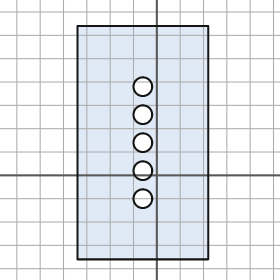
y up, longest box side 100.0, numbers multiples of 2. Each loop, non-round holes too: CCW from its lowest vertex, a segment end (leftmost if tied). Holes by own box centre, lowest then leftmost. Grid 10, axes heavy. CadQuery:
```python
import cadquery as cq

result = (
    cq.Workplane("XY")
    .moveTo(-34.0, -36.0)
    .lineTo(22.0, -36.0)
    .lineTo(22.0, 64.0)
    .lineTo(-34.0, 64.0)
    .close()
    .moveTo(-6.0, -10.0)
    .circle(4.0)
    .moveTo(-6.0, 2.0)
    .circle(4.0)
    .moveTo(-6.0, 14.0)
    .circle(4.0)
    .moveTo(-6.0, 26.0)
    .circle(4.0)
    .moveTo(-6.0, 38.0)
    .circle(4.0)
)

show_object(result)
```